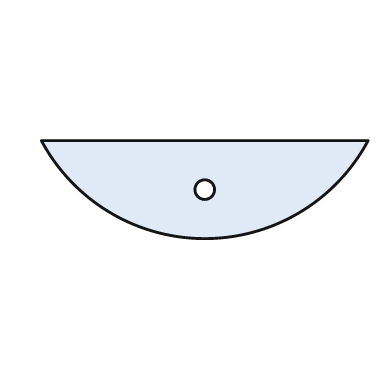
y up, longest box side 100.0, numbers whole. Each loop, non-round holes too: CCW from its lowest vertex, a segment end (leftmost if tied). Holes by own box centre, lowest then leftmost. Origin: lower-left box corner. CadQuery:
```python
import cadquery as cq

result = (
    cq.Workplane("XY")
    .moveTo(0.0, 30.0)
    .threePointArc((50.0, 0.0), (100.0, 30.0))
    .close()
    .moveTo(50.0, 15.0)
    .circle(3.0)
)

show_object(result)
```